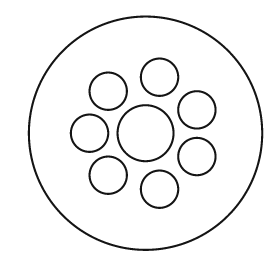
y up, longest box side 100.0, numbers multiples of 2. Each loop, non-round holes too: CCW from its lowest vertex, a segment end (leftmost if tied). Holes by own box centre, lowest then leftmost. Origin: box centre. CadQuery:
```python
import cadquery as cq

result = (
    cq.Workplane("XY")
    .moveTo(0.0, 0.0)
    .circle(50.0)
    .moveTo(6.0, -24.0)
    .circle(8.0)
    .moveTo(-16.0, -18.0)
    .circle(8.0)
    .moveTo(22.0, -10.0)
    .circle(8.0)
    .moveTo(-24.0, 0.0)
    .circle(8.0)
    .moveTo(0.0, 0.0)
    .circle(12.0)
    .moveTo(22.0, 10.0)
    .circle(8.0)
    .moveTo(-16.0, 18.0)
    .circle(8.0)
    .moveTo(6.0, 24.0)
    .circle(8.0)
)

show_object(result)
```